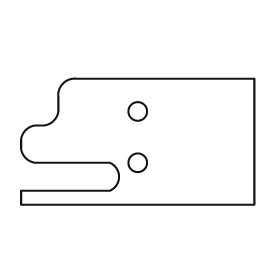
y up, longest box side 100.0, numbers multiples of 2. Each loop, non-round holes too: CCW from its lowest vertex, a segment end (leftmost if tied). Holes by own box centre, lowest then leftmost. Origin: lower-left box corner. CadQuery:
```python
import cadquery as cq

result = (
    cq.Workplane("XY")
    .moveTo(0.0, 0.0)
    .lineTo(100.0, 0.0)
    .lineTo(100.0, 54.0)
    .lineTo(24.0, 54.0)
    .threePointArc((18.0, 52.0), (16.0, 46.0))
    .lineTo(16.0, 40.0)
    .threePointArc((14.0, 36.0), (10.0, 34.0))
    .lineTo(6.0, 34.0)
    .threePointArc((2.0, 32.0), (0.0, 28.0))
    .lineTo(0.0, 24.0)
    .threePointArc((2.0, 20.0), (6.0, 18.0))
    .lineTo(38.0, 18.0)
    .threePointArc((42.0, 12.0), (38.0, 6.0))
    .lineTo(0.0, 6.0)
    .close()
    .moveTo(50.0, 18.0)
    .circle(4.0)
    .moveTo(50.0, 40.0)
    .circle(4.0)
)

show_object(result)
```